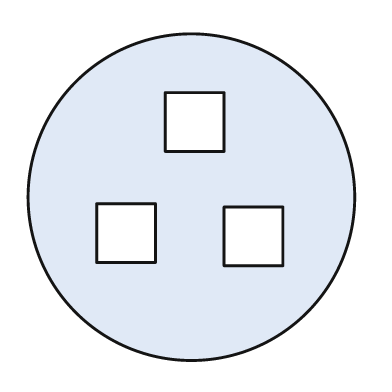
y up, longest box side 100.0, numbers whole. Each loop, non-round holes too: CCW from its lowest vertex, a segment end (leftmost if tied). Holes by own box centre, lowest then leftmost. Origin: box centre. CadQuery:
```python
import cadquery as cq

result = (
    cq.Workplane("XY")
    .moveTo(0.0, 0.0)
    .circle(50.0)
    .moveTo(10.0, -21.0)
    .lineTo(28.0, -21.0)
    .lineTo(28.0, -3.0)
    .lineTo(10.0, -3.0)
    .close()
    .moveTo(-29.0, -20.0)
    .lineTo(-11.0, -20.0)
    .lineTo(-11.0, -2.0)
    .lineTo(-29.0, -2.0)
    .close()
    .moveTo(-8.0, 14.0)
    .lineTo(10.0, 14.0)
    .lineTo(10.0, 32.0)
    .lineTo(-8.0, 32.0)
    .close()
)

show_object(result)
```